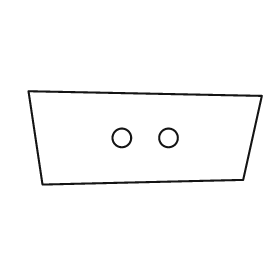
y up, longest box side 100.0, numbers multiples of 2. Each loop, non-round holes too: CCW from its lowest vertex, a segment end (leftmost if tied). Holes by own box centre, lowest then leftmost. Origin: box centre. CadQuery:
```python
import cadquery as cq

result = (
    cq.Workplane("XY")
    .moveTo(-44.0, -20.0)
    .lineTo(42.0, -18.0)
    .lineTo(50.0, 18.0)
    .lineTo(-50.0, 20.0)
    .close()
    .moveTo(-10.0, 0.0)
    .circle(4.0)
    .moveTo(10.0, 0.0)
    .circle(4.0)
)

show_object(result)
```